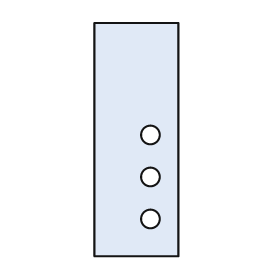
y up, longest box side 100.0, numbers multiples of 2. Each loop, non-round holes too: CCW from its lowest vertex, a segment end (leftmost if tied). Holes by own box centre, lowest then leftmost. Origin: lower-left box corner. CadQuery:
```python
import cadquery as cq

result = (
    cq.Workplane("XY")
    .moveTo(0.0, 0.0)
    .lineTo(36.0, 0.0)
    .lineTo(36.0, 100.0)
    .lineTo(0.0, 100.0)
    .close()
    .moveTo(24.0, 16.0)
    .circle(4.0)
    .moveTo(24.0, 34.0)
    .circle(4.0)
    .moveTo(24.0, 52.0)
    .circle(4.0)
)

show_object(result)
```